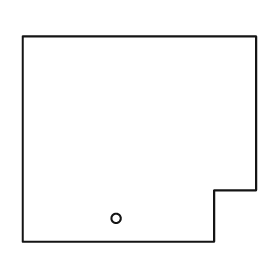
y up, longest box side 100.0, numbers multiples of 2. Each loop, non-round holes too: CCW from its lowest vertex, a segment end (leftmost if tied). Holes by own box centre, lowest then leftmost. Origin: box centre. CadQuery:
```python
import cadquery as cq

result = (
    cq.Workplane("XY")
    .moveTo(-50.0, -44.0)
    .lineTo(32.0, -44.0)
    .lineTo(32.0, -22.0)
    .lineTo(50.0, -22.0)
    .lineTo(50.0, 44.0)
    .lineTo(-50.0, 44.0)
    .close()
    .moveTo(-10.0, -34.0)
    .circle(2.0)
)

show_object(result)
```